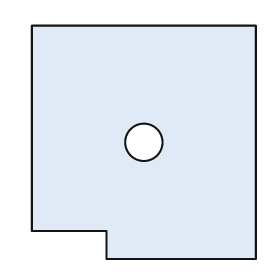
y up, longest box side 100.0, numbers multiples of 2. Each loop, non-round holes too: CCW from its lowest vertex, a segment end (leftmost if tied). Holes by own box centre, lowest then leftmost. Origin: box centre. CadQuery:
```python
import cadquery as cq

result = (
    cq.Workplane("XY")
    .moveTo(-16.0, -50.0)
    .lineTo(48.0, -50.0)
    .lineTo(48.0, 50.0)
    .lineTo(-48.0, 50.0)
    .lineTo(-48.0, -38.0)
    .lineTo(-16.0, -38.0)
    .close()
    .moveTo(0.0, 0.0)
    .circle(8.0)
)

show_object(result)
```